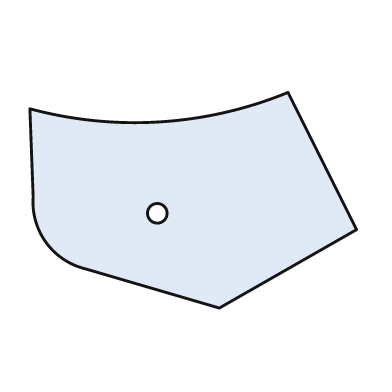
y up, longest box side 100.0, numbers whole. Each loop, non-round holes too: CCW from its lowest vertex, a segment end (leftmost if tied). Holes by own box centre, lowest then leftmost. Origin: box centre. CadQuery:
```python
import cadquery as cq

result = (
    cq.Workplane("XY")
    .moveTo(8.0, -33.0)
    .lineTo(50.0, -9.0)
    .lineTo(29.0, 33.0)
    .threePointArc((-10.0, 24.0), (-50.0, 28.0))
    .lineTo(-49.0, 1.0)
    .threePointArc((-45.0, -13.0), (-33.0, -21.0))
    .close()
    .moveTo(-11.0, -4.0)
    .circle(3.0)
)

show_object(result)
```